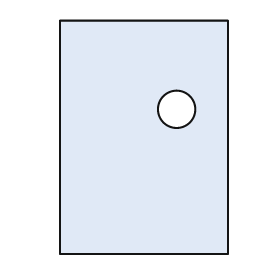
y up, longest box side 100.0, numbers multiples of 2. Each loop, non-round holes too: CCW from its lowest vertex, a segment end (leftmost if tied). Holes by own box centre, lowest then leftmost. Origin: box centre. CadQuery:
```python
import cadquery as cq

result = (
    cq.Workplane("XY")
    .moveTo(-36.0, -50.0)
    .lineTo(36.0, -50.0)
    .lineTo(36.0, 50.0)
    .lineTo(-36.0, 50.0)
    .close()
    .moveTo(14.0, 12.0)
    .circle(8.0)
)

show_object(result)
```